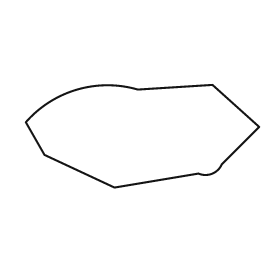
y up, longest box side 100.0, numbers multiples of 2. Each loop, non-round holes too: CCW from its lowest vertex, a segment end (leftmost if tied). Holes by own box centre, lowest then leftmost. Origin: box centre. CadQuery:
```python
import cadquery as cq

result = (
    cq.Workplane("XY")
    .moveTo(-12.0, -22.0)
    .lineTo(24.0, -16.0)
    .threePointArc((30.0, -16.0), (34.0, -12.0))
    .lineTo(50.0, 4.0)
    .lineTo(30.0, 22.0)
    .lineTo(-2.0, 20.0)
    .threePointArc((-28.0, 20.0), (-50.0, 6.0))
    .lineTo(-42.0, -8.0)
    .close()
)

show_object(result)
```